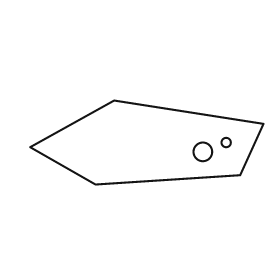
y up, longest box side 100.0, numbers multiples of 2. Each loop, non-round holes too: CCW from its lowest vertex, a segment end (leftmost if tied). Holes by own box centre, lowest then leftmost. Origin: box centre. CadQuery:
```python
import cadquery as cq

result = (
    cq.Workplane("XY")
    .moveTo(-22.0, -18.0)
    .lineTo(40.0, -14.0)
    .lineTo(50.0, 8.0)
    .lineTo(-14.0, 18.0)
    .lineTo(-50.0, -2.0)
    .close()
    .moveTo(24.0, -4.0)
    .circle(4.0)
    .moveTo(34.0, 0.0)
    .circle(2.0)
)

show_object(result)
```